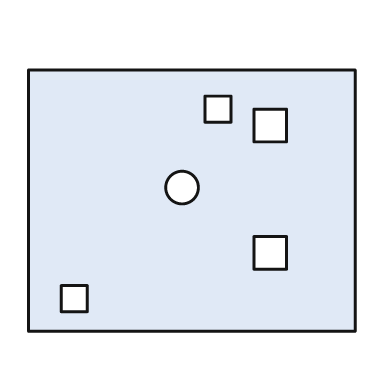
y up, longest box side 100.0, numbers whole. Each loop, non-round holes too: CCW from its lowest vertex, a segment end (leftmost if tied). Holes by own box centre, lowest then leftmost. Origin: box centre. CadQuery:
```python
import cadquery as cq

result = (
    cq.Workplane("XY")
    .moveTo(-50.0, -40.0)
    .lineTo(50.0, -40.0)
    .lineTo(50.0, 40.0)
    .lineTo(-50.0, 40.0)
    .close()
    .moveTo(-40.0, -34.0)
    .lineTo(-32.0, -34.0)
    .lineTo(-32.0, -26.0)
    .lineTo(-40.0, -26.0)
    .close()
    .moveTo(19.0, -21.0)
    .lineTo(29.0, -21.0)
    .lineTo(29.0, -11.0)
    .lineTo(19.0, -11.0)
    .close()
    .moveTo(-3.0, 4.0)
    .circle(5.0)
    .moveTo(19.0, 18.0)
    .lineTo(29.0, 18.0)
    .lineTo(29.0, 28.0)
    .lineTo(19.0, 28.0)
    .close()
    .moveTo(4.0, 24.0)
    .lineTo(12.0, 24.0)
    .lineTo(12.0, 32.0)
    .lineTo(4.0, 32.0)
    .close()
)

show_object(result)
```